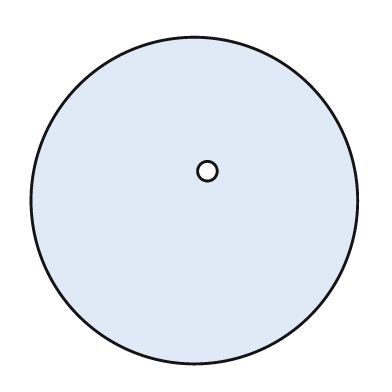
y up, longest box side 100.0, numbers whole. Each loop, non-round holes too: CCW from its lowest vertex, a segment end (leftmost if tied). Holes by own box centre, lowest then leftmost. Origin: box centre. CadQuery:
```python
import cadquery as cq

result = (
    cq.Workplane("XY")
    .moveTo(0.0, 0.0)
    .circle(50.0)
    .moveTo(4.0, 9.0)
    .circle(3.0)
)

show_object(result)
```